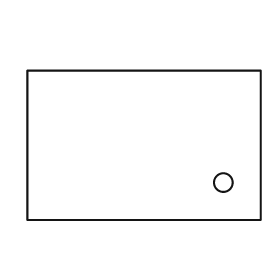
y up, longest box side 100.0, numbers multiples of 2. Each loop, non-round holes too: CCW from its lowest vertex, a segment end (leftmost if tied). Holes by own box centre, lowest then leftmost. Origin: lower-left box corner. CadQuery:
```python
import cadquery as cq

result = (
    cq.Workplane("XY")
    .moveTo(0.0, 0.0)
    .lineTo(100.0, 0.0)
    .lineTo(100.0, 64.0)
    .lineTo(0.0, 64.0)
    .close()
    .moveTo(84.0, 16.0)
    .circle(4.0)
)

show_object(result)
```